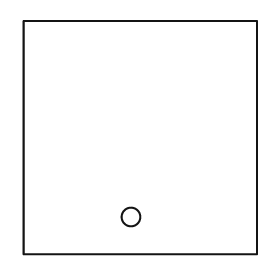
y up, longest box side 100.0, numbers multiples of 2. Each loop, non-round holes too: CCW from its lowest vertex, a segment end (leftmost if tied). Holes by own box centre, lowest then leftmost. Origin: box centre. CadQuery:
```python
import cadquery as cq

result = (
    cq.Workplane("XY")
    .moveTo(-50.0, -50.0)
    .lineTo(50.0, -50.0)
    .lineTo(50.0, 50.0)
    .lineTo(-50.0, 50.0)
    .close()
    .moveTo(-4.0, -34.0)
    .circle(4.0)
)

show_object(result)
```